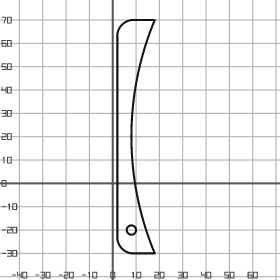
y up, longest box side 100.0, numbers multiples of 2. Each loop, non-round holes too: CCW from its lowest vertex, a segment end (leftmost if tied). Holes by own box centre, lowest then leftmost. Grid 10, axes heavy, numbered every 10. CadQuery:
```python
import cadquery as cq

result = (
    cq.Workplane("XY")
    .moveTo(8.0, -30.0)
    .lineTo(18.0, -30.0)
    .threePointArc((8.0, 20.0), (18.0, 70.0))
    .lineTo(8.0, 70.0)
    .threePointArc((4.0, 68.0), (2.0, 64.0))
    .lineTo(2.0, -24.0)
    .threePointArc((4.0, -28.0), (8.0, -30.0))
    .close()
    .moveTo(8.0, -20.0)
    .circle(2.0)
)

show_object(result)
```